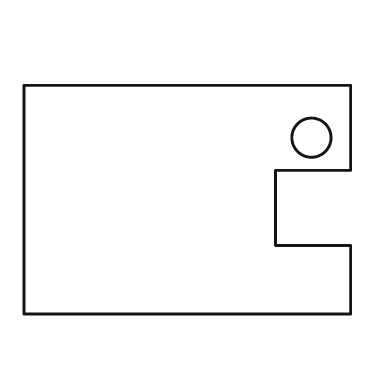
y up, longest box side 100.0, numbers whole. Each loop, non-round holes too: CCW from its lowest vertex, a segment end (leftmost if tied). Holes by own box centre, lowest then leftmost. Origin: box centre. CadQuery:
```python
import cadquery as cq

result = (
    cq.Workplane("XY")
    .moveTo(-50.0, -35.0)
    .lineTo(50.0, -35.0)
    .lineTo(50.0, -14.0)
    .lineTo(27.0, -14.0)
    .lineTo(27.0, 9.0)
    .lineTo(50.0, 9.0)
    .lineTo(50.0, 35.0)
    .lineTo(-50.0, 35.0)
    .close()
    .moveTo(38.0, 19.0)
    .circle(6.0)
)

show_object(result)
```